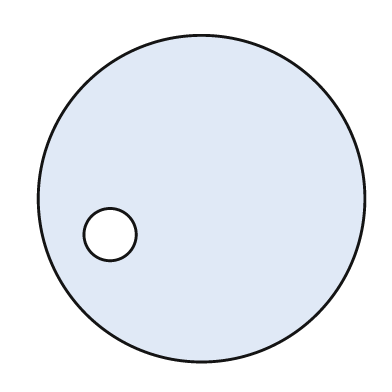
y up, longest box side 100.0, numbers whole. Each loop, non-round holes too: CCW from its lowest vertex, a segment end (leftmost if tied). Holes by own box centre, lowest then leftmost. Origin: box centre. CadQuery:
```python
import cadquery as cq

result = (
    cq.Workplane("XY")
    .moveTo(0.0, 0.0)
    .circle(50.0)
    .moveTo(-28.0, -11.0)
    .circle(8.0)
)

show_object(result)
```